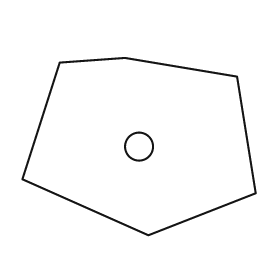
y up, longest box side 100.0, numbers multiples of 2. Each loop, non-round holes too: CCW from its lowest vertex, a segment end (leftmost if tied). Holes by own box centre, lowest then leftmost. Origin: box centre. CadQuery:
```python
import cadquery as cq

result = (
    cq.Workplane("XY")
    .moveTo(4.0, -38.0)
    .lineTo(50.0, -20.0)
    .lineTo(42.0, 30.0)
    .lineTo(-6.0, 38.0)
    .lineTo(-34.0, 36.0)
    .lineTo(-50.0, -14.0)
    .close()
    .moveTo(0.0, 0.0)
    .circle(6.0)
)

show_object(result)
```